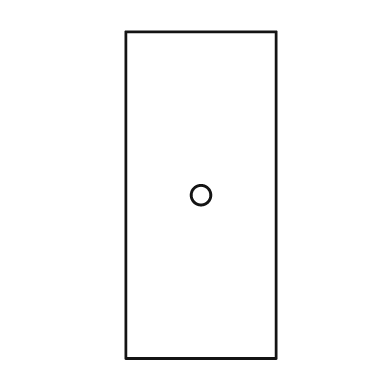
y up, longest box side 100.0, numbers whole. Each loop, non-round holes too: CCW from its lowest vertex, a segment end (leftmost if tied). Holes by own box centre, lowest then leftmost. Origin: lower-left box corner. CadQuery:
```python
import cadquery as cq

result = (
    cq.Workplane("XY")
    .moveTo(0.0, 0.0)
    .lineTo(46.0, 0.0)
    .lineTo(46.0, 100.0)
    .lineTo(0.0, 100.0)
    .close()
    .moveTo(23.0, 50.0)
    .circle(3.0)
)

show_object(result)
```